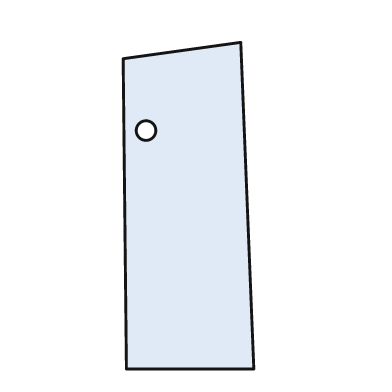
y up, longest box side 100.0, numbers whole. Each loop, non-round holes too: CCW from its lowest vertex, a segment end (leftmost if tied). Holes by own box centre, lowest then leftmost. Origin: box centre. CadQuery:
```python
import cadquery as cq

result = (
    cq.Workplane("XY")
    .moveTo(-19.0, -50.0)
    .lineTo(20.0, -50.0)
    .lineTo(16.0, 50.0)
    .lineTo(-20.0, 45.0)
    .close()
    .moveTo(-13.0, 23.0)
    .circle(3.0)
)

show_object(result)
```